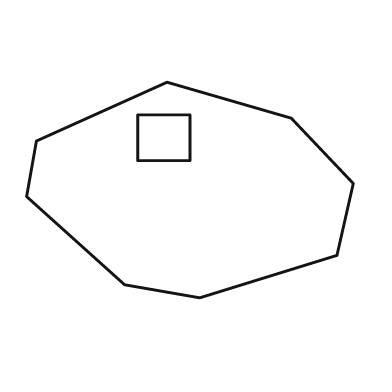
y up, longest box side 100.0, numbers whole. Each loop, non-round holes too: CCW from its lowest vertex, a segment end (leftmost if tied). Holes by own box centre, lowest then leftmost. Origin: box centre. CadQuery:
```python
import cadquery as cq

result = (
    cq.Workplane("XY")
    .moveTo(3.0, -33.0)
    .lineTo(45.0, -20.0)
    .lineTo(50.0, 2.0)
    .lineTo(31.0, 22.0)
    .lineTo(-7.0, 33.0)
    .lineTo(-47.0, 15.0)
    .lineTo(-50.0, -2.0)
    .lineTo(-20.0, -29.0)
    .close()
    .moveTo(-16.0, 9.0)
    .lineTo(0.0, 9.0)
    .lineTo(0.0, 23.0)
    .lineTo(-16.0, 23.0)
    .close()
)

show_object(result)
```